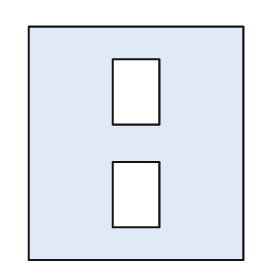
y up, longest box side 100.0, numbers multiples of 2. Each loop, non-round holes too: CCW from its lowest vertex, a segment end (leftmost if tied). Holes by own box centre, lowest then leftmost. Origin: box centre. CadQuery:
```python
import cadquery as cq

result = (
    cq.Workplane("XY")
    .moveTo(-46.0, -50.0)
    .lineTo(46.0, -50.0)
    .lineTo(46.0, 50.0)
    .lineTo(-46.0, 50.0)
    .close()
    .moveTo(-10.0, -36.0)
    .lineTo(10.0, -36.0)
    .lineTo(10.0, -8.0)
    .lineTo(-10.0, -8.0)
    .close()
    .moveTo(-10.0, 8.0)
    .lineTo(10.0, 8.0)
    .lineTo(10.0, 36.0)
    .lineTo(-10.0, 36.0)
    .close()
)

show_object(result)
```